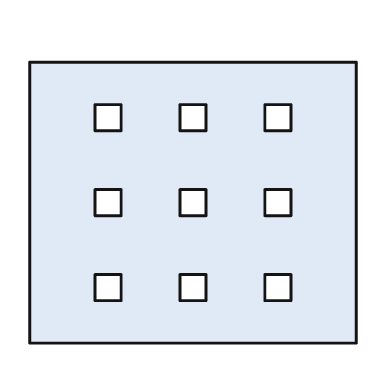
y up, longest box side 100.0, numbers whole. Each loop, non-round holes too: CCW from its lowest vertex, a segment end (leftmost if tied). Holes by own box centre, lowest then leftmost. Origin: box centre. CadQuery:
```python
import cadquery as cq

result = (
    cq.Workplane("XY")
    .moveTo(-50.0, -43.0)
    .lineTo(50.0, -43.0)
    .lineTo(50.0, 43.0)
    .lineTo(-50.0, 43.0)
    .close()
    .moveTo(-30.0, -30.0)
    .lineTo(-22.0, -30.0)
    .lineTo(-22.0, -22.0)
    .lineTo(-30.0, -22.0)
    .close()
    .moveTo(-4.0, -30.0)
    .lineTo(4.0, -30.0)
    .lineTo(4.0, -22.0)
    .lineTo(-4.0, -22.0)
    .close()
    .moveTo(22.0, -30.0)
    .lineTo(30.0, -30.0)
    .lineTo(30.0, -22.0)
    .lineTo(22.0, -22.0)
    .close()
    .moveTo(-30.0, -4.0)
    .lineTo(-22.0, -4.0)
    .lineTo(-22.0, 4.0)
    .lineTo(-30.0, 4.0)
    .close()
    .moveTo(-4.0, -4.0)
    .lineTo(4.0, -4.0)
    .lineTo(4.0, 4.0)
    .lineTo(-4.0, 4.0)
    .close()
    .moveTo(22.0, -4.0)
    .lineTo(30.0, -4.0)
    .lineTo(30.0, 4.0)
    .lineTo(22.0, 4.0)
    .close()
    .moveTo(-30.0, 22.0)
    .lineTo(-22.0, 22.0)
    .lineTo(-22.0, 30.0)
    .lineTo(-30.0, 30.0)
    .close()
    .moveTo(-4.0, 22.0)
    .lineTo(4.0, 22.0)
    .lineTo(4.0, 30.0)
    .lineTo(-4.0, 30.0)
    .close()
    .moveTo(22.0, 22.0)
    .lineTo(30.0, 22.0)
    .lineTo(30.0, 30.0)
    .lineTo(22.0, 30.0)
    .close()
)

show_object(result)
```